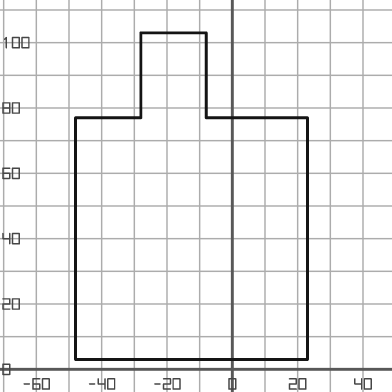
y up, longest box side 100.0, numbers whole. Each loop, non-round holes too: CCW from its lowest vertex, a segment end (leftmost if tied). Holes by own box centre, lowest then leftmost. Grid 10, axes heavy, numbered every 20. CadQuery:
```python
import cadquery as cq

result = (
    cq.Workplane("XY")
    .moveTo(-48.0, 3.0)
    .lineTo(23.0, 3.0)
    .lineTo(23.0, 77.0)
    .lineTo(-8.0, 77.0)
    .lineTo(-8.0, 103.0)
    .lineTo(-28.0, 103.0)
    .lineTo(-28.0, 77.0)
    .lineTo(-48.0, 77.0)
    .close()
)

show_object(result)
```